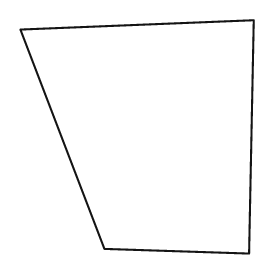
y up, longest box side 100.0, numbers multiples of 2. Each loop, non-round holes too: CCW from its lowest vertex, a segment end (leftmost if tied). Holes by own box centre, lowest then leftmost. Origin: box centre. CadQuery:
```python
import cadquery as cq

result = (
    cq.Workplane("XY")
    .moveTo(48.0, -50.0)
    .lineTo(50.0, 50.0)
    .lineTo(-50.0, 46.0)
    .lineTo(-14.0, -48.0)
    .close()
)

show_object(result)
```